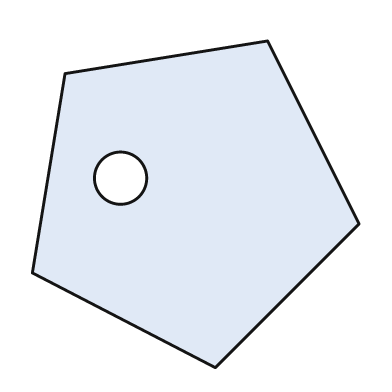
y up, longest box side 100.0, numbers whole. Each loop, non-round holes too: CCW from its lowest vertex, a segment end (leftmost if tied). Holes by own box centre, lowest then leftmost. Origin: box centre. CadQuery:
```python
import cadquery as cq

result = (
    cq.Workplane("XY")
    .moveTo(6.0, -50.0)
    .lineTo(50.0, -6.0)
    .lineTo(22.0, 50.0)
    .lineTo(-40.0, 40.0)
    .lineTo(-50.0, -21.0)
    .close()
    .moveTo(-23.0, 8.0)
    .circle(8.0)
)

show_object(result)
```